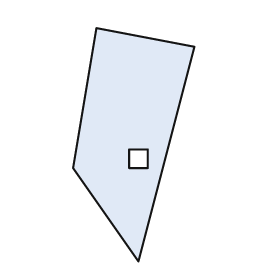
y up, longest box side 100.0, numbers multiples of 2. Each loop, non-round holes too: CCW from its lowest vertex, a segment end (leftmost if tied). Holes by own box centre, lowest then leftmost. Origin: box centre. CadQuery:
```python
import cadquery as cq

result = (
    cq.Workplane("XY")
    .moveTo(2.0, -50.0)
    .lineTo(26.0, 42.0)
    .lineTo(-16.0, 50.0)
    .lineTo(-26.0, -10.0)
    .close()
    .moveTo(-2.0, -10.0)
    .lineTo(6.0, -10.0)
    .lineTo(6.0, -2.0)
    .lineTo(-2.0, -2.0)
    .close()
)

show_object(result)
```